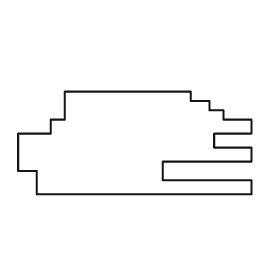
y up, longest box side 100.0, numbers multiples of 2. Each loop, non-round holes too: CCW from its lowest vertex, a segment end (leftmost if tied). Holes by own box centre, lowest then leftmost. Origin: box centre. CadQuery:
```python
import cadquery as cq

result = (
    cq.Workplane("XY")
    .moveTo(-42.0, -22.0)
    .lineTo(50.0, -22.0)
    .lineTo(50.0, -16.0)
    .lineTo(12.0, -16.0)
    .lineTo(12.0, -8.0)
    .lineTo(50.0, -8.0)
    .lineTo(50.0, -2.0)
    .lineTo(34.0, -2.0)
    .lineTo(34.0, 4.0)
    .lineTo(50.0, 4.0)
    .lineTo(50.0, 10.0)
    .lineTo(38.0, 10.0)
    .lineTo(38.0, 14.0)
    .lineTo(32.0, 14.0)
    .lineTo(32.0, 18.0)
    .lineTo(24.0, 18.0)
    .lineTo(24.0, 22.0)
    .lineTo(-30.0, 22.0)
    .lineTo(-30.0, 10.0)
    .lineTo(-36.0, 10.0)
    .lineTo(-36.0, 4.0)
    .lineTo(-50.0, 4.0)
    .lineTo(-50.0, -12.0)
    .lineTo(-42.0, -12.0)
    .close()
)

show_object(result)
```